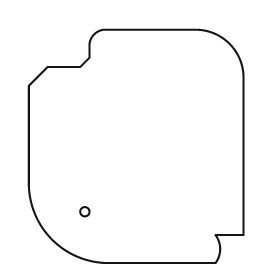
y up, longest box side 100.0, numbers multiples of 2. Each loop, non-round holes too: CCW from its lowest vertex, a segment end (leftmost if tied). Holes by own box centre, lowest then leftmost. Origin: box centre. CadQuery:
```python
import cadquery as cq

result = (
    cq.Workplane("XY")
    .moveTo(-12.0, -50.0)
    .lineTo(34.0, -50.0)
    .threePointArc((36.0, -44.0), (34.0, -38.0))
    .lineTo(46.0, -38.0)
    .lineTo(46.0, 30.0)
    .threePointArc((40.0, 44.0), (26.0, 50.0))
    .lineTo(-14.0, 50.0)
    .threePointArc((-18.0, 48.0), (-20.0, 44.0))
    .lineTo(-20.0, 38.0)
    .lineTo(-24.0, 34.0)
    .lineTo(-38.0, 34.0)
    .lineTo(-46.0, 26.0)
    .lineTo(-46.0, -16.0)
    .threePointArc((-36.0, -40.0), (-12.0, -50.0))
    .close()
    .moveTo(-22.0, -28.0)
    .circle(2.0)
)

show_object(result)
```